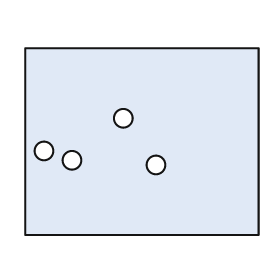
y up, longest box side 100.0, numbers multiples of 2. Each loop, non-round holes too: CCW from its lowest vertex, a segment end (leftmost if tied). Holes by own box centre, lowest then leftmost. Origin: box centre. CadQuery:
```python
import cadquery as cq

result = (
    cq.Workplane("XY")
    .moveTo(-50.0, -40.0)
    .lineTo(50.0, -40.0)
    .lineTo(50.0, 40.0)
    .lineTo(-50.0, 40.0)
    .close()
    .moveTo(6.0, -10.0)
    .circle(4.0)
    .moveTo(-30.0, -8.0)
    .circle(4.0)
    .moveTo(-42.0, -4.0)
    .circle(4.0)
    .moveTo(-8.0, 10.0)
    .circle(4.0)
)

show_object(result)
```